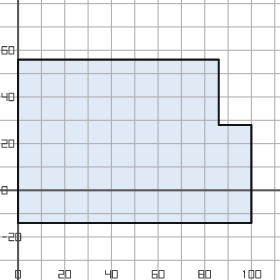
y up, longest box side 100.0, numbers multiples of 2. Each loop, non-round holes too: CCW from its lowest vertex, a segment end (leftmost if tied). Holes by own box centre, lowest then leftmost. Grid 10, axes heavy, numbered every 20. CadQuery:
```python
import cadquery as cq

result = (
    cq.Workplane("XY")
    .moveTo(0.0, -14.0)
    .lineTo(100.0, -14.0)
    .lineTo(100.0, 28.0)
    .lineTo(86.0, 28.0)
    .lineTo(86.0, 56.0)
    .lineTo(0.0, 56.0)
    .close()
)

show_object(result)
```